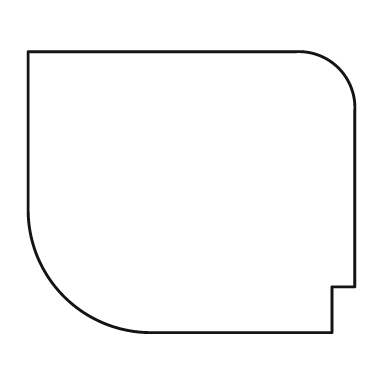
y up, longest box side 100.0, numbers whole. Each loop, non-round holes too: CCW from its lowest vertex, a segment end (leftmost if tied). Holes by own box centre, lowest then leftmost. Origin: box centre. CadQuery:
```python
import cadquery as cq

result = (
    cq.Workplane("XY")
    .moveTo(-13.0, -43.0)
    .lineTo(43.0, -43.0)
    .lineTo(43.0, -29.0)
    .lineTo(50.0, -29.0)
    .lineTo(50.0, 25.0)
    .threePointArc((45.0, 38.0), (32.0, 43.0))
    .lineTo(-50.0, 43.0)
    .lineTo(-50.0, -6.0)
    .threePointArc((-39.0, -32.0), (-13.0, -43.0))
    .close()
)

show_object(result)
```